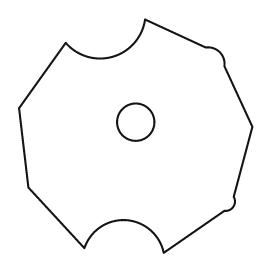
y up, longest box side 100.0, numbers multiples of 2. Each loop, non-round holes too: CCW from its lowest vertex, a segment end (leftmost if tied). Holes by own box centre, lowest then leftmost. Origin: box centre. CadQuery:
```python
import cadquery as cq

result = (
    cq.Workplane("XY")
    .moveTo(12.0, -50.0)
    .lineTo(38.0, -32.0)
    .threePointArc((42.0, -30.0), (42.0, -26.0))
    .lineTo(50.0, 4.0)
    .lineTo(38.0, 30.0)
    .threePointArc((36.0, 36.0), (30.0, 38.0))
    .lineTo(4.0, 50.0)
    .threePointArc((-10.0, 34.0), (-30.0, 40.0))
    .lineTo(-50.0, 12.0)
    .lineTo(-46.0, -22.0)
    .lineTo(-22.0, -48.0)
    .threePointArc((-4.0, -36.0), (12.0, -50.0))
    .close()
    .moveTo(0.0, 6.0)
    .circle(8.0)
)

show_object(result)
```